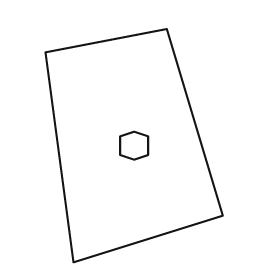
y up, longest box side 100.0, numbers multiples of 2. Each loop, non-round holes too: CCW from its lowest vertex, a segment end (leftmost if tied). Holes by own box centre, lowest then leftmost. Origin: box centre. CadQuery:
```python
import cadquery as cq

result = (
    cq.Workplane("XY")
    .moveTo(-26.0, -50.0)
    .lineTo(38.0, -30.0)
    .lineTo(14.0, 50.0)
    .lineTo(-38.0, 40.0)
    .close()
    .moveTo(0.0, -6.0)
    .lineTo(6.0, -4.0)
    .lineTo(6.0, 4.0)
    .lineTo(0.0, 6.0)
    .lineTo(-6.0, 4.0)
    .lineTo(-6.0, -4.0)
    .close()
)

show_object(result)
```